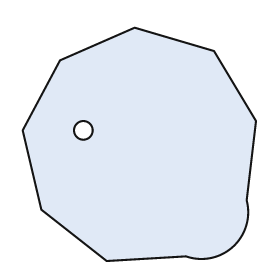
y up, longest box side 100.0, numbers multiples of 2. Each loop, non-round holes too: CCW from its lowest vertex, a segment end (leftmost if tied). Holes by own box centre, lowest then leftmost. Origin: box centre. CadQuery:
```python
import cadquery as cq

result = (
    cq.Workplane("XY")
    .moveTo(-14.0, -50.0)
    .lineTo(20.0, -48.0)
    .threePointArc((40.0, -44.0), (46.0, -24.0))
    .lineTo(50.0, 10.0)
    .lineTo(32.0, 40.0)
    .lineTo(-2.0, 50.0)
    .lineTo(-34.0, 36.0)
    .lineTo(-50.0, 6.0)
    .lineTo(-42.0, -28.0)
    .close()
    .moveTo(-24.0, 6.0)
    .circle(4.0)
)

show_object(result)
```